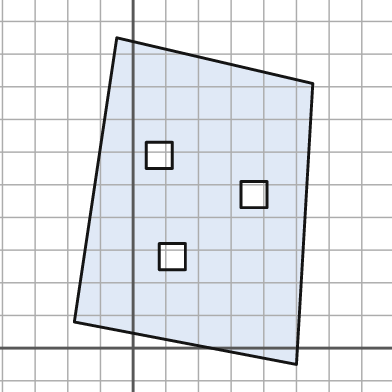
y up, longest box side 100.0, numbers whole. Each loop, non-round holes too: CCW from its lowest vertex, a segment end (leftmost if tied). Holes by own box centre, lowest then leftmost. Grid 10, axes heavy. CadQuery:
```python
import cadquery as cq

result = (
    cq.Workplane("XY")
    .moveTo(50.0, -5.0)
    .lineTo(55.0, 81.0)
    .lineTo(-5.0, 95.0)
    .lineTo(-18.0, 8.0)
    .close()
    .moveTo(8.0, 24.0)
    .lineTo(16.0, 24.0)
    .lineTo(16.0, 32.0)
    .lineTo(8.0, 32.0)
    .close()
    .moveTo(33.0, 43.0)
    .lineTo(41.0, 43.0)
    .lineTo(41.0, 51.0)
    .lineTo(33.0, 51.0)
    .close()
    .moveTo(4.0, 55.0)
    .lineTo(12.0, 55.0)
    .lineTo(12.0, 63.0)
    .lineTo(4.0, 63.0)
    .close()
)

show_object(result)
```